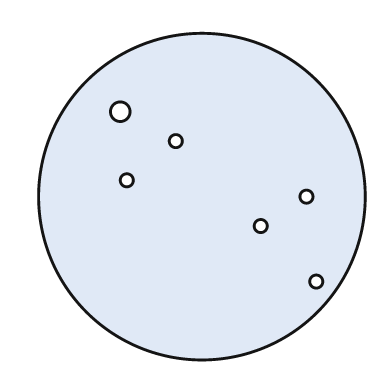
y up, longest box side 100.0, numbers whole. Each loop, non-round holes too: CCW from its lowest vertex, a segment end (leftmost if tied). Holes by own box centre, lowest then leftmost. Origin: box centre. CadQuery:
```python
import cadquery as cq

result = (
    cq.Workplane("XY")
    .moveTo(0.0, 0.0)
    .circle(50.0)
    .moveTo(35.0, -26.0)
    .circle(2.0)
    .moveTo(18.0, -9.0)
    .circle(2.0)
    .moveTo(32.0, 0.0)
    .circle(2.0)
    .moveTo(-23.0, 5.0)
    .circle(2.0)
    .moveTo(-8.0, 17.0)
    .circle(2.0)
    .moveTo(-25.0, 26.0)
    .circle(3.0)
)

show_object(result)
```